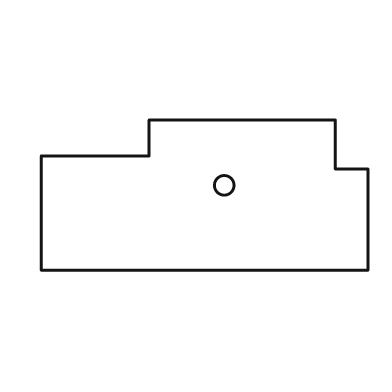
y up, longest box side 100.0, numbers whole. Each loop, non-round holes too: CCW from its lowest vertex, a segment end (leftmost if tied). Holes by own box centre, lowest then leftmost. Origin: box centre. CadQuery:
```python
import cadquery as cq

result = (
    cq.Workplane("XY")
    .moveTo(-50.0, -23.0)
    .lineTo(50.0, -23.0)
    .lineTo(50.0, 8.0)
    .lineTo(40.0, 8.0)
    .lineTo(40.0, 23.0)
    .lineTo(-17.0, 23.0)
    .lineTo(-17.0, 12.0)
    .lineTo(-50.0, 12.0)
    .close()
    .moveTo(6.0, 3.0)
    .circle(3.0)
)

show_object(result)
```